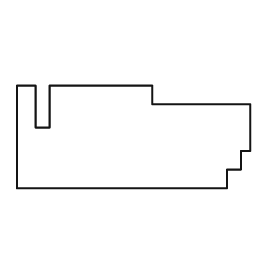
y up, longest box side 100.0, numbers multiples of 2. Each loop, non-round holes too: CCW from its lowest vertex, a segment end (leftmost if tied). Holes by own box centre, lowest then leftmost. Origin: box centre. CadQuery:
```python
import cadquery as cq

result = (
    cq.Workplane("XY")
    .moveTo(-50.0, -22.0)
    .lineTo(40.0, -22.0)
    .lineTo(40.0, -14.0)
    .lineTo(46.0, -14.0)
    .lineTo(46.0, -6.0)
    .lineTo(50.0, -6.0)
    .lineTo(50.0, 14.0)
    .lineTo(8.0, 14.0)
    .lineTo(8.0, 22.0)
    .lineTo(-36.0, 22.0)
    .lineTo(-36.0, 4.0)
    .lineTo(-42.0, 4.0)
    .lineTo(-42.0, 22.0)
    .lineTo(-50.0, 22.0)
    .close()
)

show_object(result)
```